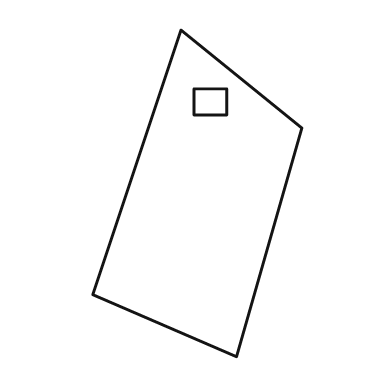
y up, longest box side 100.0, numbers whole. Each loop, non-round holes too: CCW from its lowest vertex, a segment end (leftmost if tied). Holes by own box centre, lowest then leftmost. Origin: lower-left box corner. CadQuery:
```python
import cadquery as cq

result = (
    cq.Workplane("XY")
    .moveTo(44.0, 0.0)
    .lineTo(64.0, 70.0)
    .lineTo(27.0, 100.0)
    .lineTo(0.0, 19.0)
    .close()
    .moveTo(31.0, 74.0)
    .lineTo(41.0, 74.0)
    .lineTo(41.0, 82.0)
    .lineTo(31.0, 82.0)
    .close()
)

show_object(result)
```